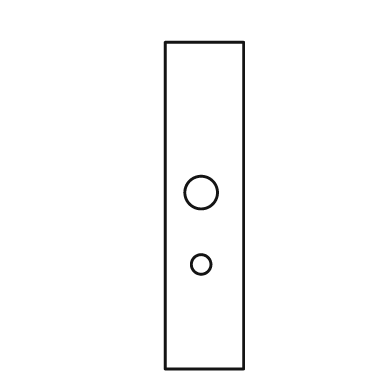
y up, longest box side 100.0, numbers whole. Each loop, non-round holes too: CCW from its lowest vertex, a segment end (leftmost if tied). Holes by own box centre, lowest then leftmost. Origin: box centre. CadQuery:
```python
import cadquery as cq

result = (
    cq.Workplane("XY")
    .moveTo(-12.0, -50.0)
    .lineTo(12.0, -50.0)
    .lineTo(12.0, 50.0)
    .lineTo(-12.0, 50.0)
    .close()
    .moveTo(-1.0, -18.0)
    .circle(3.0)
    .moveTo(-1.0, 4.0)
    .circle(5.0)
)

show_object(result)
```